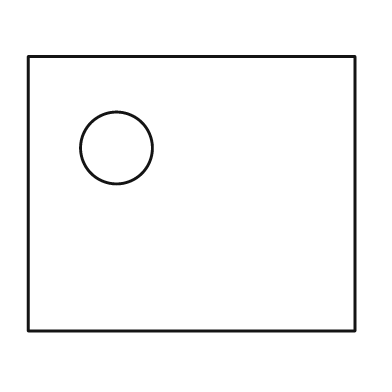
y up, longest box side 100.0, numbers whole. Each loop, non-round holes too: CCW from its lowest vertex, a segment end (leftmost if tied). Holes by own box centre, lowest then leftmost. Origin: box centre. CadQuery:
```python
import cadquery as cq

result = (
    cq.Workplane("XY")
    .moveTo(-50.0, -42.0)
    .lineTo(50.0, -42.0)
    .lineTo(50.0, 42.0)
    .lineTo(-50.0, 42.0)
    .close()
    .moveTo(-23.0, 14.0)
    .circle(11.0)
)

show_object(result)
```